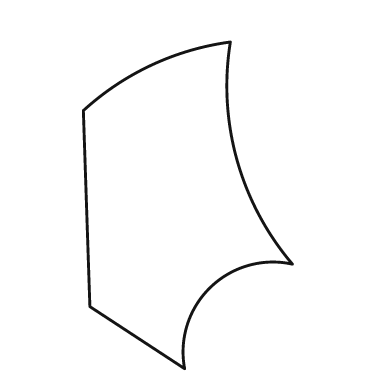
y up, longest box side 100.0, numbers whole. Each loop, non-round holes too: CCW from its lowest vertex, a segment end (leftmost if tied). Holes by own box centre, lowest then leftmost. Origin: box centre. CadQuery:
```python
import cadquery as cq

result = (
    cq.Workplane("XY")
    .moveTo(-1.0, -50.0)
    .threePointArc((7.0, -25.0), (32.0, -18.0))
    .threePointArc((15.0, 14.0), (13.0, 50.0))
    .threePointArc((-11.0, 43.0), (-32.0, 29.0))
    .lineTo(-30.0, -31.0)
    .close()
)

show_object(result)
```